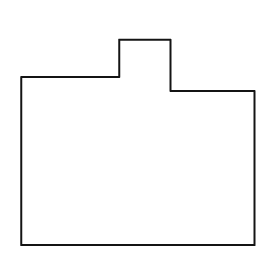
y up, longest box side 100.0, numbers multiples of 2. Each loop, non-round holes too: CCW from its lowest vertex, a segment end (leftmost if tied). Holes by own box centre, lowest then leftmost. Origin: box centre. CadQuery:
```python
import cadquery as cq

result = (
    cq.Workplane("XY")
    .moveTo(-50.0, -44.0)
    .lineTo(50.0, -44.0)
    .lineTo(50.0, 22.0)
    .lineTo(14.0, 22.0)
    .lineTo(14.0, 44.0)
    .lineTo(-8.0, 44.0)
    .lineTo(-8.0, 28.0)
    .lineTo(-50.0, 28.0)
    .close()
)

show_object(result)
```